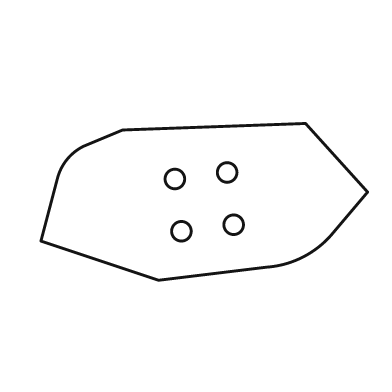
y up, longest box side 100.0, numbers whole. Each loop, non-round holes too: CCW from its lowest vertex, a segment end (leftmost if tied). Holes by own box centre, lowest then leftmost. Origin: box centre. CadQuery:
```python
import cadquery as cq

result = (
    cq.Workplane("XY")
    .moveTo(-14.0, -24.0)
    .lineTo(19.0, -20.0)
    .threePointArc((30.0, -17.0), (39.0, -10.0))
    .lineTo(50.0, 3.0)
    .lineTo(31.0, 24.0)
    .lineTo(-25.0, 22.0)
    .lineTo(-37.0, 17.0)
    .threePointArc((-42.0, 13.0), (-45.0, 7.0))
    .lineTo(-50.0, -12.0)
    .close()
    .moveTo(-7.0, -9.0)
    .circle(3.0)
    .moveTo(9.0, -7.0)
    .circle(3.0)
    .moveTo(-9.0, 7.0)
    .circle(3.0)
    .moveTo(7.0, 9.0)
    .circle(3.0)
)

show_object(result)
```